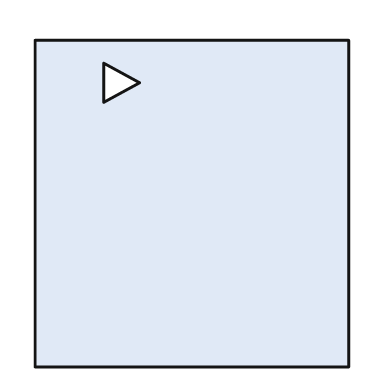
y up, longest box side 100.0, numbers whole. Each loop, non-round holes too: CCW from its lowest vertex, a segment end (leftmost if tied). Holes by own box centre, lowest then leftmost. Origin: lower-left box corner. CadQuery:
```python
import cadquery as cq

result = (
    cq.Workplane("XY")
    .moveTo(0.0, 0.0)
    .lineTo(96.0, 0.0)
    .lineTo(96.0, 100.0)
    .lineTo(0.0, 100.0)
    .close()
    .moveTo(21.0, 81.0)
    .lineTo(32.0, 87.0)
    .lineTo(21.0, 93.0)
    .close()
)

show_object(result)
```